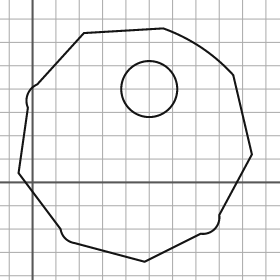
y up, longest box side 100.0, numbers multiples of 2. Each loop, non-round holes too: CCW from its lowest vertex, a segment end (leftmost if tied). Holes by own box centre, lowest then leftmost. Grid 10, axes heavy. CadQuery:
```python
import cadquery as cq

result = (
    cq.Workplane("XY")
    .moveTo(48.0, -34.0)
    .lineTo(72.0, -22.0)
    .threePointArc((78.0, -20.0), (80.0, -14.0))
    .lineTo(94.0, 12.0)
    .lineTo(86.0, 46.0)
    .threePointArc((72.0, 58.0), (56.0, 66.0))
    .lineTo(22.0, 64.0)
    .lineTo(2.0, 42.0)
    .threePointArc((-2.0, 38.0), (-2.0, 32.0))
    .lineTo(-6.0, 4.0)
    .lineTo(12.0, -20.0)
    .threePointArc((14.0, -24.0), (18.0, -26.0))
    .close()
    .moveTo(50.0, 40.0)
    .circle(12.0)
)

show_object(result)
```